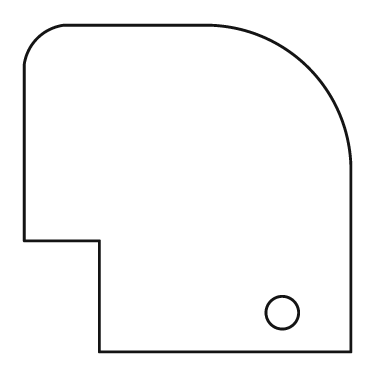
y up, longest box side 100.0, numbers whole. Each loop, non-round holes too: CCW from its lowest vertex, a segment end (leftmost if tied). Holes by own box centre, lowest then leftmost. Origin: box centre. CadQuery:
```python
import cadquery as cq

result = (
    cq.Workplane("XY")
    .moveTo(-27.0, -50.0)
    .lineTo(50.0, -50.0)
    .lineTo(50.0, 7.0)
    .threePointArc((37.0, 37.0), (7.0, 50.0))
    .lineTo(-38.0, 50.0)
    .threePointArc((-46.0, 46.0), (-50.0, 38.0))
    .lineTo(-50.0, -16.0)
    .lineTo(-27.0, -16.0)
    .close()
    .moveTo(29.0, -38.0)
    .circle(5.0)
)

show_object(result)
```